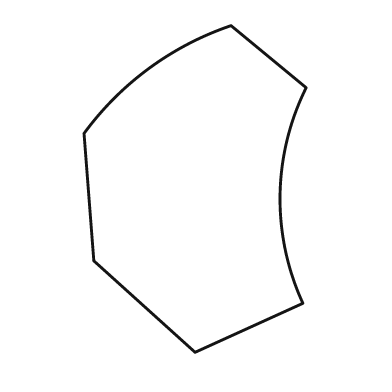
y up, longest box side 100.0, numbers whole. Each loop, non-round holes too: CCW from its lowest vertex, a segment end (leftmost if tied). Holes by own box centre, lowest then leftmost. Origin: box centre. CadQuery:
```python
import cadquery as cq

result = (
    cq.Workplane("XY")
    .moveTo(0.0, -50.0)
    .lineTo(33.0, -35.0)
    .threePointArc((26.0, -2.0), (34.0, 31.0))
    .lineTo(11.0, 50.0)
    .threePointArc((-14.0, 37.0), (-34.0, 17.0))
    .lineTo(-31.0, -22.0)
    .close()
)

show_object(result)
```